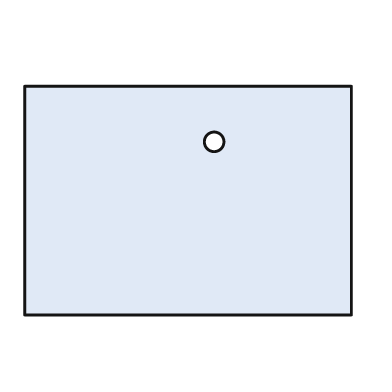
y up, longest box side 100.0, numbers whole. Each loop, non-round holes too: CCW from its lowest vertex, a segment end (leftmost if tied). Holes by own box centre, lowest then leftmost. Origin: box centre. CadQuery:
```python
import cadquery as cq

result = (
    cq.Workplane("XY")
    .moveTo(-50.0, -35.0)
    .lineTo(50.0, -35.0)
    .lineTo(50.0, 35.0)
    .lineTo(-50.0, 35.0)
    .close()
    .moveTo(8.0, 18.0)
    .circle(3.0)
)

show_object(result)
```